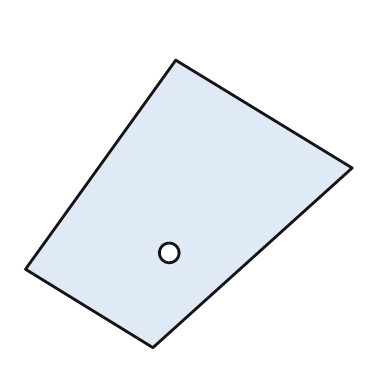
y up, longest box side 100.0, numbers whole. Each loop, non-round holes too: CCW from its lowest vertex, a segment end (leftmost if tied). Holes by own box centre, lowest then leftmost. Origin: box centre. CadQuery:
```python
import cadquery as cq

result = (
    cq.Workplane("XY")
    .moveTo(-11.0, -44.0)
    .lineTo(50.0, 11.0)
    .lineTo(-4.0, 44.0)
    .lineTo(-50.0, -20.0)
    .close()
    .moveTo(-6.0, -15.0)
    .circle(3.0)
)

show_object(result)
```